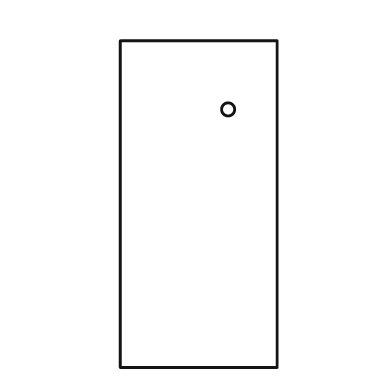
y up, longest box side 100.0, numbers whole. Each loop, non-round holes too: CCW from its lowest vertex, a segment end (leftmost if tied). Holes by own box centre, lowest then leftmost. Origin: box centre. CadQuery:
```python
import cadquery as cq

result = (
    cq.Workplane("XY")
    .moveTo(-24.0, -50.0)
    .lineTo(24.0, -50.0)
    .lineTo(24.0, 50.0)
    .lineTo(-24.0, 50.0)
    .close()
    .moveTo(9.0, 29.0)
    .circle(2.0)
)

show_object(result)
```